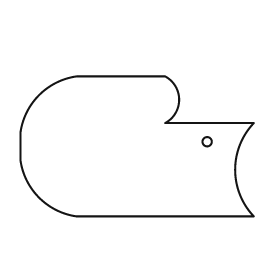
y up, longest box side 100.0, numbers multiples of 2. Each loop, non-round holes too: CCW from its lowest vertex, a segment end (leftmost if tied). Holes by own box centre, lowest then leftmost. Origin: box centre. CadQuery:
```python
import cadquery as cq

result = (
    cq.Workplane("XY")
    .moveTo(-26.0, -30.0)
    .lineTo(50.0, -30.0)
    .threePointArc((42.0, -10.0), (50.0, 10.0))
    .lineTo(12.0, 10.0)
    .threePointArc((18.0, 20.0), (12.0, 30.0))
    .lineTo(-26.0, 30.0)
    .threePointArc((-42.0, 22.0), (-50.0, 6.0))
    .lineTo(-50.0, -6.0)
    .threePointArc((-42.0, -22.0), (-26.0, -30.0))
    .close()
    .moveTo(30.0, 2.0)
    .circle(2.0)
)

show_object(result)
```